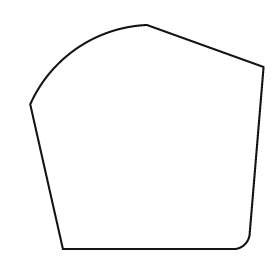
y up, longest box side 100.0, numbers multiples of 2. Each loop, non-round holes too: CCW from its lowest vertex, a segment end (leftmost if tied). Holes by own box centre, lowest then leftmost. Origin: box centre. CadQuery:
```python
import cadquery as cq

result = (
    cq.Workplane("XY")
    .moveTo(-36.0, -48.0)
    .lineTo(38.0, -48.0)
    .threePointArc((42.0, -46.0), (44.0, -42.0))
    .lineTo(50.0, 30.0)
    .lineTo(0.0, 48.0)
    .threePointArc((-30.0, 38.0), (-50.0, 14.0))
    .close()
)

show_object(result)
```